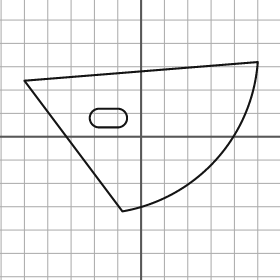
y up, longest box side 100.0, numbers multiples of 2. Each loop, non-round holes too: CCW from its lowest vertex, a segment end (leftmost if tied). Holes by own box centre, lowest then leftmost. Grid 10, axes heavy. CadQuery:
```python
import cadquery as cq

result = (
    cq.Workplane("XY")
    .moveTo(-8.0, -32.0)
    .threePointArc((32.0, -10.0), (50.0, 32.0))
    .lineTo(-50.0, 24.0)
    .close()
    .moveTo(-18.0, 4.0)
    .lineTo(-10.0, 4.0)
    .threePointArc((-6.0, 8.0), (-10.0, 12.0))
    .lineTo(-18.0, 12.0)
    .threePointArc((-22.0, 8.0), (-18.0, 4.0))
    .close()
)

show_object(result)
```